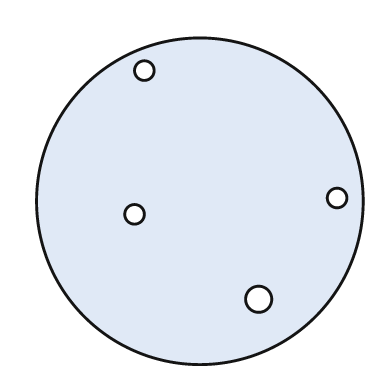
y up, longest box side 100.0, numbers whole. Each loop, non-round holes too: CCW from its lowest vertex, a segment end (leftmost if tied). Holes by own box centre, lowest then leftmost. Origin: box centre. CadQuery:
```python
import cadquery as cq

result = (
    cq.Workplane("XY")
    .moveTo(0.0, 0.0)
    .circle(50.0)
    .moveTo(18.0, -30.0)
    .circle(4.0)
    .moveTo(-20.0, -4.0)
    .circle(3.0)
    .moveTo(42.0, 1.0)
    .circle(3.0)
    .moveTo(-17.0, 40.0)
    .circle(3.0)
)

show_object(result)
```